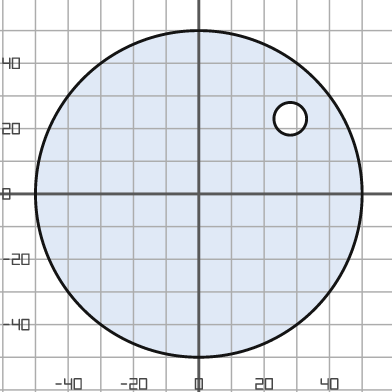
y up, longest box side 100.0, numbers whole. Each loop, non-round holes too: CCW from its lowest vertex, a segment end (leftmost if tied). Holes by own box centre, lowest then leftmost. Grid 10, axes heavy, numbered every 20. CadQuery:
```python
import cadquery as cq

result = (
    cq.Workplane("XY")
    .moveTo(0.0, 0.0)
    .circle(50.0)
    .moveTo(28.0, 23.0)
    .circle(5.0)
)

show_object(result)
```